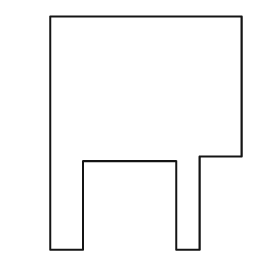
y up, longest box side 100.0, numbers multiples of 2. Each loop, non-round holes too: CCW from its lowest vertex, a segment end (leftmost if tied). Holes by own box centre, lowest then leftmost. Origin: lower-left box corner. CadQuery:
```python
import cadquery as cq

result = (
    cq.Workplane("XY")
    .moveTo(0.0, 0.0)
    .lineTo(14.0, 0.0)
    .lineTo(14.0, 38.0)
    .lineTo(54.0, 38.0)
    .lineTo(54.0, 0.0)
    .lineTo(64.0, 0.0)
    .lineTo(64.0, 40.0)
    .lineTo(82.0, 40.0)
    .lineTo(82.0, 100.0)
    .lineTo(0.0, 100.0)
    .close()
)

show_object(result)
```